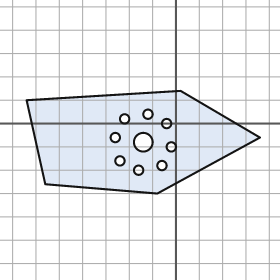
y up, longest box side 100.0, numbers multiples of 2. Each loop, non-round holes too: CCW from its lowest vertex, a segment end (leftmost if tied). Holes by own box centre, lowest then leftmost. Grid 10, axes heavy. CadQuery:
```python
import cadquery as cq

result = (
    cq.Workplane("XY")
    .moveTo(-8.0, -30.0)
    .lineTo(36.0, -6.0)
    .lineTo(2.0, 14.0)
    .lineTo(-64.0, 10.0)
    .lineTo(-56.0, -26.0)
    .close()
    .moveTo(-16.0, -20.0)
    .circle(2.0)
    .moveTo(-6.0, -18.0)
    .circle(2.0)
    .moveTo(-24.0, -16.0)
    .circle(2.0)
    .moveTo(-2.0, -10.0)
    .circle(2.0)
    .moveTo(-14.0, -8.0)
    .circle(4.0)
    .moveTo(-26.0, -6.0)
    .circle(2.0)
    .moveTo(-4.0, 0.0)
    .circle(2.0)
    .moveTo(-22.0, 2.0)
    .circle(2.0)
    .moveTo(-12.0, 4.0)
    .circle(2.0)
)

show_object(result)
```